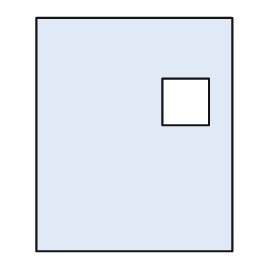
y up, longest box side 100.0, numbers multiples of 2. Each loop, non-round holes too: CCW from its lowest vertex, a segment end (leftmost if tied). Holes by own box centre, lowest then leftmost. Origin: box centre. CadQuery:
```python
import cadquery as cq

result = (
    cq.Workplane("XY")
    .moveTo(-42.0, -50.0)
    .lineTo(42.0, -50.0)
    .lineTo(42.0, 50.0)
    .lineTo(-42.0, 50.0)
    .close()
    .moveTo(12.0, 4.0)
    .lineTo(32.0, 4.0)
    .lineTo(32.0, 24.0)
    .lineTo(12.0, 24.0)
    .close()
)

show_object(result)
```